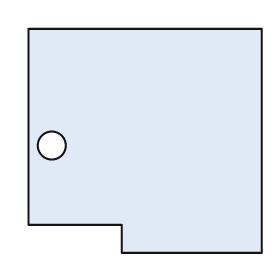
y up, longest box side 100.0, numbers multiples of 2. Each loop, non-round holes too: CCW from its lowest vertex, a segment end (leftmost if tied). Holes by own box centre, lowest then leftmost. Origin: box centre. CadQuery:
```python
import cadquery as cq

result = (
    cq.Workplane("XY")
    .moveTo(-10.0, -48.0)
    .lineTo(50.0, -48.0)
    .lineTo(50.0, 48.0)
    .lineTo(-50.0, 48.0)
    .lineTo(-50.0, -36.0)
    .lineTo(-10.0, -36.0)
    .close()
    .moveTo(-40.0, -2.0)
    .circle(6.0)
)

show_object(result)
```